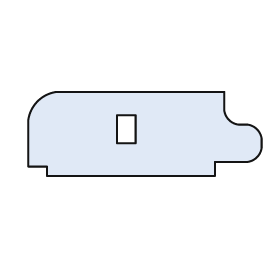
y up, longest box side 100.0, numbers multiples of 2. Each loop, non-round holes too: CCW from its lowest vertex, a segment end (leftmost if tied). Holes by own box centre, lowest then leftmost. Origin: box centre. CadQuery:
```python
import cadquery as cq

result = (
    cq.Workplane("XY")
    .moveTo(-42.0, -18.0)
    .lineTo(30.0, -18.0)
    .lineTo(30.0, -12.0)
    .lineTo(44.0, -12.0)
    .threePointArc((48.0, -10.0), (50.0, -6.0))
    .lineTo(50.0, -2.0)
    .threePointArc((48.0, 2.0), (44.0, 4.0))
    .lineTo(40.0, 4.0)
    .threePointArc((36.0, 6.0), (34.0, 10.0))
    .lineTo(34.0, 18.0)
    .lineTo(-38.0, 18.0)
    .threePointArc((-46.0, 14.0), (-50.0, 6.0))
    .lineTo(-50.0, -14.0)
    .lineTo(-42.0, -14.0)
    .close()
    .moveTo(-12.0, -4.0)
    .lineTo(-4.0, -4.0)
    .lineTo(-4.0, 8.0)
    .lineTo(-12.0, 8.0)
    .close()
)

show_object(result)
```